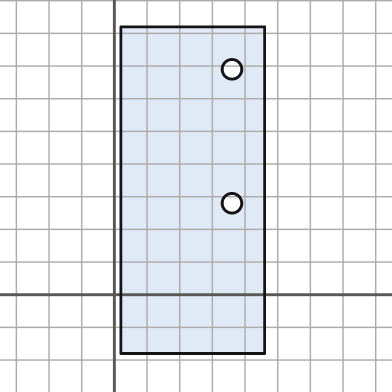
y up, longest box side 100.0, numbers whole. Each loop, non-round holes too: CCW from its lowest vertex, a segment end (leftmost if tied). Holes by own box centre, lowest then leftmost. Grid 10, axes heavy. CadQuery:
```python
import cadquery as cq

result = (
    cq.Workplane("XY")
    .moveTo(2.0, -18.0)
    .lineTo(46.0, -18.0)
    .lineTo(46.0, 82.0)
    .lineTo(2.0, 82.0)
    .close()
    .moveTo(36.0, 28.0)
    .circle(3.0)
    .moveTo(36.0, 69.0)
    .circle(3.0)
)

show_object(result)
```